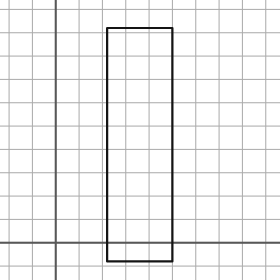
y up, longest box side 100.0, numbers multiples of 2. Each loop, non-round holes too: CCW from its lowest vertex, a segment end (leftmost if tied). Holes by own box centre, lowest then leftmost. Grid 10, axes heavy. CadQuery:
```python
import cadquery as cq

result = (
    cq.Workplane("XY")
    .moveTo(22.0, -8.0)
    .lineTo(50.0, -8.0)
    .lineTo(50.0, 92.0)
    .lineTo(22.0, 92.0)
    .close()
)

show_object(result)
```